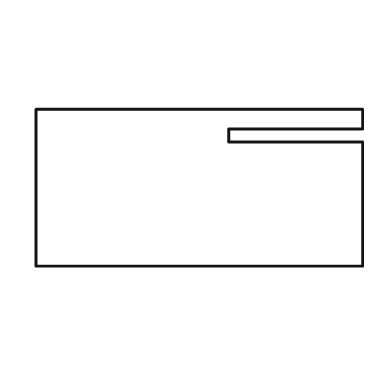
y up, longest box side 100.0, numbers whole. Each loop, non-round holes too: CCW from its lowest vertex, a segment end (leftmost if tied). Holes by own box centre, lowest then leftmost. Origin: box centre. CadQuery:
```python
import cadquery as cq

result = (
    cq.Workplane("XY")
    .moveTo(-50.0, -24.0)
    .lineTo(50.0, -24.0)
    .lineTo(50.0, 14.0)
    .lineTo(9.0, 14.0)
    .lineTo(9.0, 18.0)
    .lineTo(50.0, 18.0)
    .lineTo(50.0, 24.0)
    .lineTo(-50.0, 24.0)
    .close()
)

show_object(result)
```